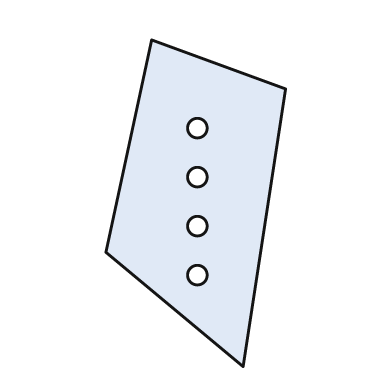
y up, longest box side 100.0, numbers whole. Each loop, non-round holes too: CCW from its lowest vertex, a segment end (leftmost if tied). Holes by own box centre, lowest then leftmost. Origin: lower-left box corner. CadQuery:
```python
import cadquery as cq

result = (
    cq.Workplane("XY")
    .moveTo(42.0, 0.0)
    .lineTo(55.0, 85.0)
    .lineTo(14.0, 100.0)
    .lineTo(0.0, 35.0)
    .close()
    .moveTo(28.0, 28.0)
    .circle(3.0)
    .moveTo(28.0, 43.0)
    .circle(3.0)
    .moveTo(28.0, 58.0)
    .circle(3.0)
    .moveTo(28.0, 73.0)
    .circle(3.0)
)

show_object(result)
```